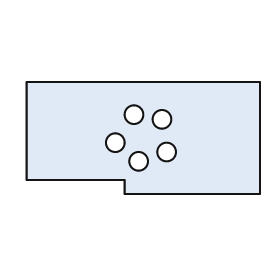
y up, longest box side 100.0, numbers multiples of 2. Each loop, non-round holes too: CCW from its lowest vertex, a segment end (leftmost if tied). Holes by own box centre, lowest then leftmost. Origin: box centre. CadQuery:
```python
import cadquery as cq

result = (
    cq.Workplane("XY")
    .moveTo(-8.0, -24.0)
    .lineTo(50.0, -24.0)
    .lineTo(50.0, 24.0)
    .lineTo(-50.0, 24.0)
    .lineTo(-50.0, -18.0)
    .lineTo(-8.0, -18.0)
    .close()
    .moveTo(-2.0, -10.0)
    .circle(4.0)
    .moveTo(10.0, -6.0)
    .circle(4.0)
    .moveTo(-12.0, -2.0)
    .circle(4.0)
    .moveTo(8.0, 8.0)
    .circle(4.0)
    .moveTo(-4.0, 10.0)
    .circle(4.0)
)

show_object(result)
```